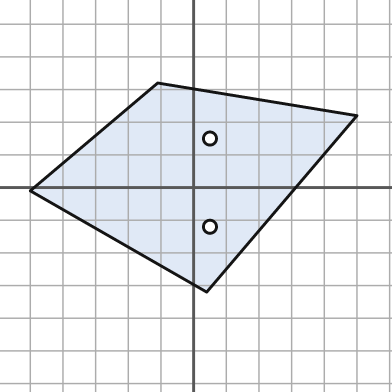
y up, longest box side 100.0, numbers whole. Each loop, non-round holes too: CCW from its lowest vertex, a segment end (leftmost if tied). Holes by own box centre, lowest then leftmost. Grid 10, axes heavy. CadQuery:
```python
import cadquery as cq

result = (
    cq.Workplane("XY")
    .moveTo(4.0, -32.0)
    .lineTo(50.0, 22.0)
    .lineTo(-11.0, 32.0)
    .lineTo(-50.0, -1.0)
    .close()
    .moveTo(5.0, -12.0)
    .circle(2.0)
    .moveTo(5.0, 15.0)
    .circle(2.0)
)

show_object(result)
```